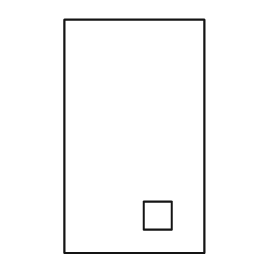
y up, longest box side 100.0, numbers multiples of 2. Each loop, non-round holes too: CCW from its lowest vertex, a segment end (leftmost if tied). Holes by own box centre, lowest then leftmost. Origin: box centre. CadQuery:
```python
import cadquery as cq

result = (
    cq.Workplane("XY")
    .moveTo(-30.0, -50.0)
    .lineTo(30.0, -50.0)
    .lineTo(30.0, 50.0)
    .lineTo(-30.0, 50.0)
    .close()
    .moveTo(4.0, -40.0)
    .lineTo(16.0, -40.0)
    .lineTo(16.0, -28.0)
    .lineTo(4.0, -28.0)
    .close()
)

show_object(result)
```